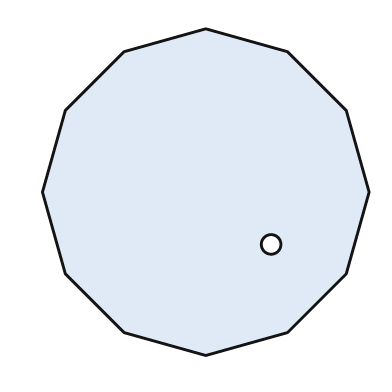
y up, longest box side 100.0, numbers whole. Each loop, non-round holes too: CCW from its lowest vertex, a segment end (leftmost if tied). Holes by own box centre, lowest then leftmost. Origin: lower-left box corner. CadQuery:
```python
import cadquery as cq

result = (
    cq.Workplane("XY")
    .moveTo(50.0, 0.0)
    .lineTo(75.0, 7.0)
    .lineTo(93.0, 25.0)
    .lineTo(100.0, 50.0)
    .lineTo(93.0, 75.0)
    .lineTo(75.0, 93.0)
    .lineTo(50.0, 100.0)
    .lineTo(25.0, 93.0)
    .lineTo(7.0, 75.0)
    .lineTo(0.0, 50.0)
    .lineTo(7.0, 25.0)
    .lineTo(25.0, 7.0)
    .close()
    .moveTo(70.0, 34.0)
    .circle(3.0)
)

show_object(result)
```